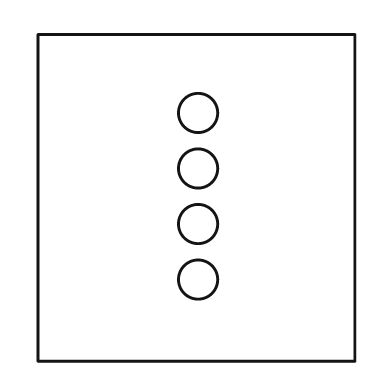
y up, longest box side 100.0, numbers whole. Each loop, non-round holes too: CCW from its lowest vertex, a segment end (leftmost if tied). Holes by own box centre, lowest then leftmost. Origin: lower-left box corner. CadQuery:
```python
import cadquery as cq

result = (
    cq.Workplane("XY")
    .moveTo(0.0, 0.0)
    .lineTo(97.0, 0.0)
    .lineTo(97.0, 100.0)
    .lineTo(0.0, 100.0)
    .close()
    .moveTo(49.0, 25.0)
    .circle(6.0)
    .moveTo(49.0, 42.0)
    .circle(6.0)
    .moveTo(49.0, 59.0)
    .circle(6.0)
    .moveTo(49.0, 76.0)
    .circle(6.0)
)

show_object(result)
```